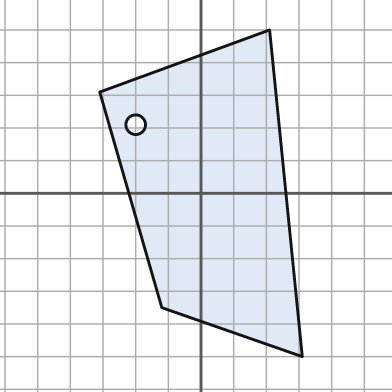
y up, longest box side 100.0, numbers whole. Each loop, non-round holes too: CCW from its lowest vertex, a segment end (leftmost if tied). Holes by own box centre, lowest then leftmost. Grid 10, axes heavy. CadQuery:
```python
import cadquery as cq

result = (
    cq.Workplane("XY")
    .moveTo(31.0, -50.0)
    .lineTo(21.0, 50.0)
    .lineTo(-31.0, 31.0)
    .lineTo(-12.0, -35.0)
    .close()
    .moveTo(-20.0, 21.0)
    .circle(3.0)
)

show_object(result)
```